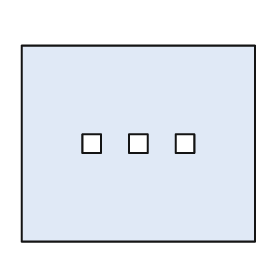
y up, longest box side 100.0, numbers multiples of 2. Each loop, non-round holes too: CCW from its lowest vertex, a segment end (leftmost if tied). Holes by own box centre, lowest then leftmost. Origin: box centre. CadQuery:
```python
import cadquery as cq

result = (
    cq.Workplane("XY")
    .moveTo(-50.0, -42.0)
    .lineTo(50.0, -42.0)
    .lineTo(50.0, 42.0)
    .lineTo(-50.0, 42.0)
    .close()
    .moveTo(-24.0, -4.0)
    .lineTo(-16.0, -4.0)
    .lineTo(-16.0, 4.0)
    .lineTo(-24.0, 4.0)
    .close()
    .moveTo(-4.0, -4.0)
    .lineTo(4.0, -4.0)
    .lineTo(4.0, 4.0)
    .lineTo(-4.0, 4.0)
    .close()
    .moveTo(16.0, -4.0)
    .lineTo(24.0, -4.0)
    .lineTo(24.0, 4.0)
    .lineTo(16.0, 4.0)
    .close()
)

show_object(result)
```